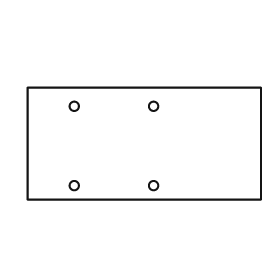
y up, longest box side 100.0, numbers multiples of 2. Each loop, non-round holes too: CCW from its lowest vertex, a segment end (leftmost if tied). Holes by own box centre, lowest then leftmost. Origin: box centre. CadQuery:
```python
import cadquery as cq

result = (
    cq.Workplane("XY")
    .moveTo(-50.0, -24.0)
    .lineTo(50.0, -24.0)
    .lineTo(50.0, 24.0)
    .lineTo(-50.0, 24.0)
    .close()
    .moveTo(-30.0, -18.0)
    .circle(2.0)
    .moveTo(4.0, -18.0)
    .circle(2.0)
    .moveTo(-30.0, 16.0)
    .circle(2.0)
    .moveTo(4.0, 16.0)
    .circle(2.0)
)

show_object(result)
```